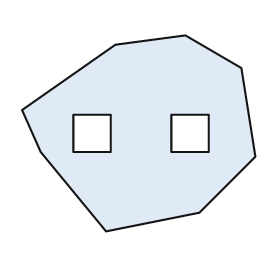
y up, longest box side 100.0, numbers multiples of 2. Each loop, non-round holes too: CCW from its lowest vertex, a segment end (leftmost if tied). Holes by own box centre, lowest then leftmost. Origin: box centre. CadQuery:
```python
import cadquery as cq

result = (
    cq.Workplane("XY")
    .moveTo(-14.0, -42.0)
    .lineTo(26.0, -34.0)
    .lineTo(50.0, -10.0)
    .lineTo(44.0, 28.0)
    .lineTo(20.0, 42.0)
    .lineTo(-10.0, 38.0)
    .lineTo(-50.0, 10.0)
    .lineTo(-42.0, -8.0)
    .close()
    .moveTo(-28.0, -8.0)
    .lineTo(-12.0, -8.0)
    .lineTo(-12.0, 8.0)
    .lineTo(-28.0, 8.0)
    .close()
    .moveTo(14.0, -8.0)
    .lineTo(30.0, -8.0)
    .lineTo(30.0, 8.0)
    .lineTo(14.0, 8.0)
    .close()
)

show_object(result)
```